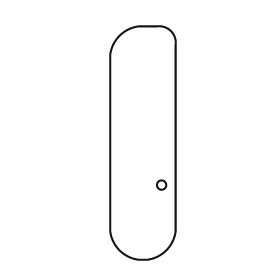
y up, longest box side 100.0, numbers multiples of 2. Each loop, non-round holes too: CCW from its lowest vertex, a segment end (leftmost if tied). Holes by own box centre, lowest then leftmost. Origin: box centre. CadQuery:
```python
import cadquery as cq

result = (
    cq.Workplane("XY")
    .moveTo(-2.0, -50.0)
    .lineTo(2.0, -50.0)
    .threePointArc((10.0, -46.0), (14.0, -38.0))
    .lineTo(14.0, 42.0)
    .threePointArc((12.0, 48.0), (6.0, 50.0))
    .lineTo(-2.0, 50.0)
    .threePointArc((-10.0, 46.0), (-14.0, 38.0))
    .lineTo(-14.0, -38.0)
    .threePointArc((-10.0, -46.0), (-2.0, -50.0))
    .close()
    .moveTo(8.0, -18.0)
    .circle(2.0)
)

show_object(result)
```